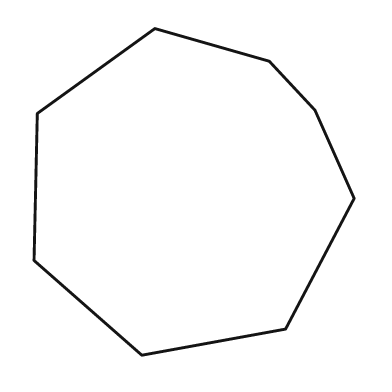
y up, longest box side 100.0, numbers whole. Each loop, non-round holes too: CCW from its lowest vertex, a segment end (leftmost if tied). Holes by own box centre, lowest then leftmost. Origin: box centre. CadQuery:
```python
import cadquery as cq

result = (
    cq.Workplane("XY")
    .moveTo(-16.0, -50.0)
    .lineTo(28.0, -42.0)
    .lineTo(49.0, -2.0)
    .lineTo(37.0, 25.0)
    .lineTo(23.0, 40.0)
    .lineTo(-12.0, 50.0)
    .lineTo(-48.0, 24.0)
    .lineTo(-49.0, -21.0)
    .close()
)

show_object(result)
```